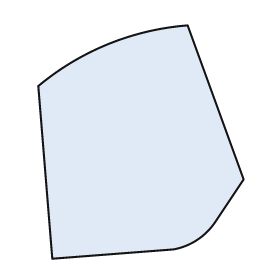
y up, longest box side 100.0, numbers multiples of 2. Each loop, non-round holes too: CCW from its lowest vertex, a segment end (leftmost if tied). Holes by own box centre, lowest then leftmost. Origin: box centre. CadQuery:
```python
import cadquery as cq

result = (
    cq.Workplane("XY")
    .moveTo(-38.0, -50.0)
    .lineTo(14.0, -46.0)
    .threePointArc((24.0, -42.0), (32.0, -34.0))
    .lineTo(44.0, -16.0)
    .lineTo(20.0, 50.0)
    .threePointArc((-14.0, 42.0), (-44.0, 24.0))
    .close()
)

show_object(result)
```